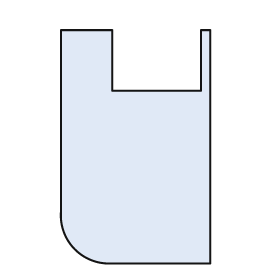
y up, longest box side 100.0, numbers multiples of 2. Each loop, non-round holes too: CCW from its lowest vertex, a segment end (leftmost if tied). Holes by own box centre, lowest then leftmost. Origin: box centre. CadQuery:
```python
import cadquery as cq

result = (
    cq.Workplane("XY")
    .moveTo(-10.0, -50.0)
    .lineTo(32.0, -50.0)
    .lineTo(32.0, 50.0)
    .lineTo(28.0, 50.0)
    .lineTo(28.0, 24.0)
    .lineTo(-10.0, 24.0)
    .lineTo(-10.0, 50.0)
    .lineTo(-32.0, 50.0)
    .lineTo(-32.0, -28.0)
    .threePointArc((-26.0, -44.0), (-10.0, -50.0))
    .close()
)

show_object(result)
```